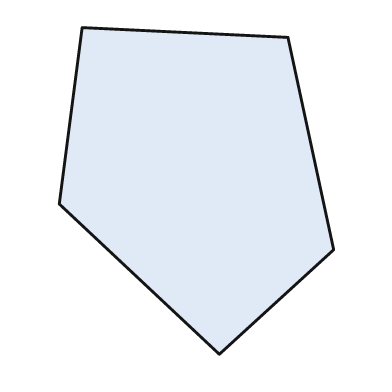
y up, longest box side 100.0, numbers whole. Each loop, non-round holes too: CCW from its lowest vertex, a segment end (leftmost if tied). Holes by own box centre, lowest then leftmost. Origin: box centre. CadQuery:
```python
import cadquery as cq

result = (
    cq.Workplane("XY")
    .moveTo(7.0, -50.0)
    .lineTo(42.0, -18.0)
    .lineTo(28.0, 47.0)
    .lineTo(-35.0, 50.0)
    .lineTo(-42.0, -4.0)
    .close()
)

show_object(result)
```